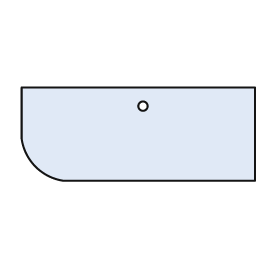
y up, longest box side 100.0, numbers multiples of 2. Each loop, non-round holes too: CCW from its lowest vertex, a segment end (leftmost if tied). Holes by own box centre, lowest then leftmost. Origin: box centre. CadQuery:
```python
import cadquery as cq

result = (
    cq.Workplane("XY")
    .moveTo(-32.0, -20.0)
    .lineTo(50.0, -20.0)
    .lineTo(50.0, 20.0)
    .lineTo(-50.0, 20.0)
    .lineTo(-50.0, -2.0)
    .threePointArc((-44.0, -14.0), (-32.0, -20.0))
    .close()
    .moveTo(2.0, 12.0)
    .circle(2.0)
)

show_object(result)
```